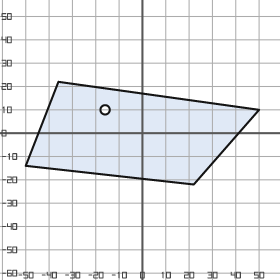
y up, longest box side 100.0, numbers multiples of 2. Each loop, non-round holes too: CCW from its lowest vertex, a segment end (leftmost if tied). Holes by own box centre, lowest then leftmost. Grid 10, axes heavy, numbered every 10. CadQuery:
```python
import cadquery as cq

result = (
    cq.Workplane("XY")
    .moveTo(22.0, -22.0)
    .lineTo(50.0, 10.0)
    .lineTo(-36.0, 22.0)
    .lineTo(-50.0, -14.0)
    .close()
    .moveTo(-16.0, 10.0)
    .circle(2.0)
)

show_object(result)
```